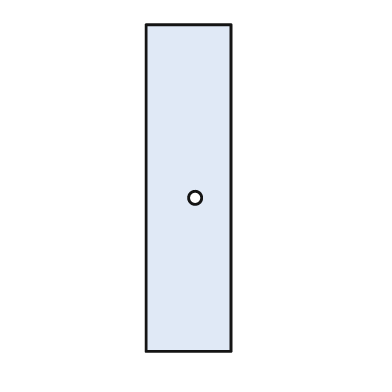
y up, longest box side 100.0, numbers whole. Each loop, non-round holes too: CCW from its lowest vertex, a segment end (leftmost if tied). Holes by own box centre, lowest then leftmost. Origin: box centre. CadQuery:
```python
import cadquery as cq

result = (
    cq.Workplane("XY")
    .moveTo(-13.0, -50.0)
    .lineTo(13.0, -50.0)
    .lineTo(13.0, 50.0)
    .lineTo(-13.0, 50.0)
    .close()
    .moveTo(2.0, -3.0)
    .circle(2.0)
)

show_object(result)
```